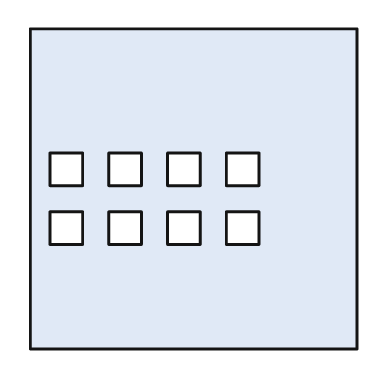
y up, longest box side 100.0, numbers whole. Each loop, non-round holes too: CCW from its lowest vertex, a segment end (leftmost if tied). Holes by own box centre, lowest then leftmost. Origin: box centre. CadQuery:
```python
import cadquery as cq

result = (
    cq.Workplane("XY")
    .moveTo(-50.0, -49.0)
    .lineTo(50.0, -49.0)
    .lineTo(50.0, 49.0)
    .lineTo(-50.0, 49.0)
    .close()
    .moveTo(-44.0, -17.0)
    .lineTo(-34.0, -17.0)
    .lineTo(-34.0, -7.0)
    .lineTo(-44.0, -7.0)
    .close()
    .moveTo(-26.0, -17.0)
    .lineTo(-16.0, -17.0)
    .lineTo(-16.0, -7.0)
    .lineTo(-26.0, -7.0)
    .close()
    .moveTo(-8.0, -17.0)
    .lineTo(2.0, -17.0)
    .lineTo(2.0, -7.0)
    .lineTo(-8.0, -7.0)
    .close()
    .moveTo(10.0, -17.0)
    .lineTo(20.0, -17.0)
    .lineTo(20.0, -7.0)
    .lineTo(10.0, -7.0)
    .close()
    .moveTo(-44.0, 1.0)
    .lineTo(-34.0, 1.0)
    .lineTo(-34.0, 11.0)
    .lineTo(-44.0, 11.0)
    .close()
    .moveTo(-26.0, 1.0)
    .lineTo(-16.0, 1.0)
    .lineTo(-16.0, 11.0)
    .lineTo(-26.0, 11.0)
    .close()
    .moveTo(-8.0, 1.0)
    .lineTo(2.0, 1.0)
    .lineTo(2.0, 11.0)
    .lineTo(-8.0, 11.0)
    .close()
    .moveTo(10.0, 1.0)
    .lineTo(20.0, 1.0)
    .lineTo(20.0, 11.0)
    .lineTo(10.0, 11.0)
    .close()
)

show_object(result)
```